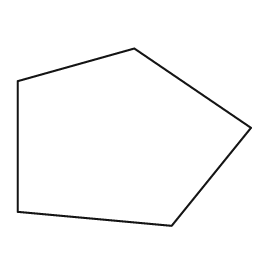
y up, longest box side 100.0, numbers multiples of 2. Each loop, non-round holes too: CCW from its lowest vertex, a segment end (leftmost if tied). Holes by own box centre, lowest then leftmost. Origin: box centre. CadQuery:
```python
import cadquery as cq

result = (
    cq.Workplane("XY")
    .moveTo(16.0, -38.0)
    .lineTo(50.0, 4.0)
    .lineTo(0.0, 38.0)
    .lineTo(-50.0, 24.0)
    .lineTo(-50.0, -32.0)
    .close()
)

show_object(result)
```